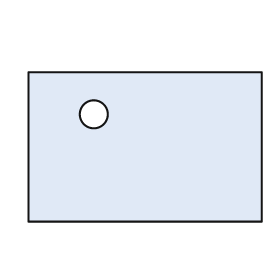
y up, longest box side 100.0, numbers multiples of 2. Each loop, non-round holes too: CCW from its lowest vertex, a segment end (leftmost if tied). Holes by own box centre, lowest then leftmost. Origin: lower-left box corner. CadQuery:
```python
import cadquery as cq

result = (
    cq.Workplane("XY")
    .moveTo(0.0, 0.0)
    .lineTo(100.0, 0.0)
    .lineTo(100.0, 64.0)
    .lineTo(0.0, 64.0)
    .close()
    .moveTo(28.0, 46.0)
    .circle(6.0)
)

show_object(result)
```